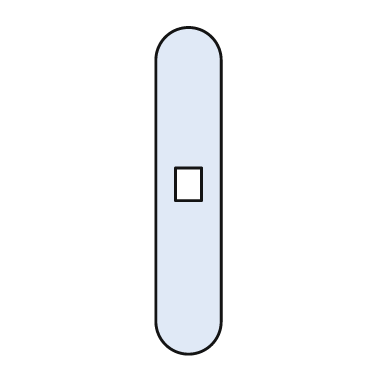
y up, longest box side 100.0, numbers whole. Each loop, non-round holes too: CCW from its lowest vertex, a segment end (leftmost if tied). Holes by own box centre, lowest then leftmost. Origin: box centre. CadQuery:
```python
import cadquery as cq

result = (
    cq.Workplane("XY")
    .moveTo(-10.0, -40.0)
    .threePointArc((0.0, -50.0), (10.0, -40.0))
    .lineTo(10.0, 40.0)
    .threePointArc((0.0, 50.0), (-10.0, 40.0))
    .close()
    .moveTo(-4.0, -3.0)
    .lineTo(4.0, -3.0)
    .lineTo(4.0, 7.0)
    .lineTo(-4.0, 7.0)
    .close()
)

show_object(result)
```